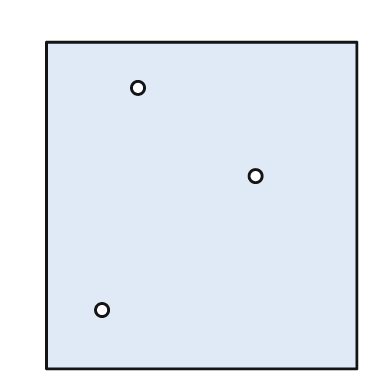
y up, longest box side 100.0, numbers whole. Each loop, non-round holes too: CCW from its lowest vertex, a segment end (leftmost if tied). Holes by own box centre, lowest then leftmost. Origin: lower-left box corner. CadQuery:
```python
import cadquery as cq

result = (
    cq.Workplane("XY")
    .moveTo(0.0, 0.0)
    .lineTo(95.0, 0.0)
    .lineTo(95.0, 100.0)
    .lineTo(0.0, 100.0)
    .close()
    .moveTo(17.0, 18.0)
    .circle(2.0)
    .moveTo(64.0, 59.0)
    .circle(2.0)
    .moveTo(28.0, 86.0)
    .circle(2.0)
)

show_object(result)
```